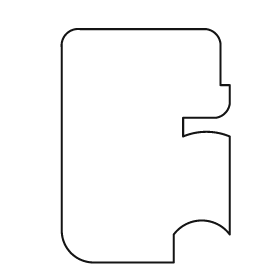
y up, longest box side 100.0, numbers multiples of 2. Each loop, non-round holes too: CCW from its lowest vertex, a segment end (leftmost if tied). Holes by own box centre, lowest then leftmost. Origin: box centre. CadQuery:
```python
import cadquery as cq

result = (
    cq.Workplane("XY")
    .moveTo(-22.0, -50.0)
    .lineTo(12.0, -50.0)
    .lineTo(12.0, -38.0)
    .threePointArc((24.0, -32.0), (36.0, -38.0))
    .lineTo(36.0, 4.0)
    .threePointArc((26.0, 6.0), (16.0, 4.0))
    .lineTo(16.0, 12.0)
    .lineTo(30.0, 12.0)
    .threePointArc((34.0, 14.0), (36.0, 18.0))
    .lineTo(36.0, 26.0)
    .lineTo(32.0, 26.0)
    .lineTo(32.0, 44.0)
    .threePointArc((30.0, 48.0), (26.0, 50.0))
    .lineTo(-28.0, 50.0)
    .threePointArc((-34.0, 48.0), (-36.0, 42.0))
    .lineTo(-36.0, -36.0)
    .threePointArc((-32.0, -46.0), (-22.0, -50.0))
    .close()
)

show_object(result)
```